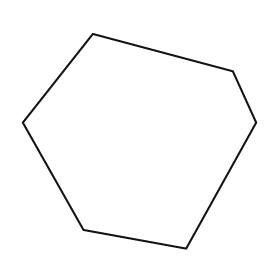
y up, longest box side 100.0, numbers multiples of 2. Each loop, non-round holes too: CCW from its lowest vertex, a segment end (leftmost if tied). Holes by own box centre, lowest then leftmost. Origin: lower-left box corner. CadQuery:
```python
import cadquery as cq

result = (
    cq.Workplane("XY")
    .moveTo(70.0, 0.0)
    .lineTo(100.0, 54.0)
    .lineTo(90.0, 76.0)
    .lineTo(30.0, 92.0)
    .lineTo(0.0, 54.0)
    .lineTo(26.0, 8.0)
    .close()
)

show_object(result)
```